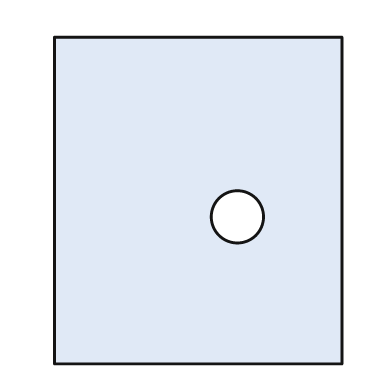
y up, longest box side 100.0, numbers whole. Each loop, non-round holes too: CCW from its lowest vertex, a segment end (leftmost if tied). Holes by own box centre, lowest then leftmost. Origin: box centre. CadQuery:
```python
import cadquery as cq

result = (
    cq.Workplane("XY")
    .moveTo(-44.0, -50.0)
    .lineTo(44.0, -50.0)
    .lineTo(44.0, 50.0)
    .lineTo(-44.0, 50.0)
    .close()
    .moveTo(12.0, -5.0)
    .circle(8.0)
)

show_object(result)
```